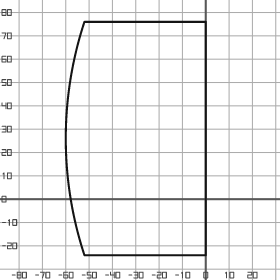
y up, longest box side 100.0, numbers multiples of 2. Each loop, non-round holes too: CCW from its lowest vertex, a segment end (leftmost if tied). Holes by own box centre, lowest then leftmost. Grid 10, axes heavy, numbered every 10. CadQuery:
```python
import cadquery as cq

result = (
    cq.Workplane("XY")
    .moveTo(-52.0, -24.0)
    .lineTo(0.0, -24.0)
    .lineTo(0.0, 76.0)
    .lineTo(-52.0, 76.0)
    .threePointArc((-60.0, 26.0), (-52.0, -24.0))
    .close()
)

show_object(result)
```